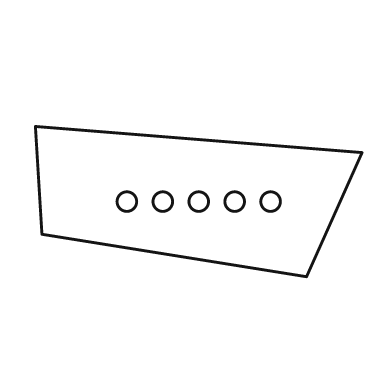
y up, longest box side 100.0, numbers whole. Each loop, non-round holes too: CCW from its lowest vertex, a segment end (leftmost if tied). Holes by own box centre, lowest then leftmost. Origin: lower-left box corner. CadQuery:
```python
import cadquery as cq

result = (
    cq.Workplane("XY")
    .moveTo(83.0, 0.0)
    .lineTo(100.0, 38.0)
    .lineTo(0.0, 46.0)
    .lineTo(2.0, 13.0)
    .close()
    .moveTo(28.0, 23.0)
    .circle(3.0)
    .moveTo(39.0, 23.0)
    .circle(3.0)
    .moveTo(50.0, 23.0)
    .circle(3.0)
    .moveTo(61.0, 23.0)
    .circle(3.0)
    .moveTo(72.0, 23.0)
    .circle(3.0)
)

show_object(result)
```